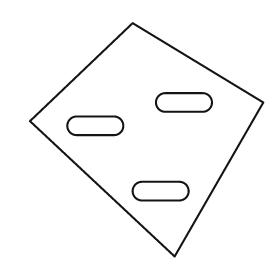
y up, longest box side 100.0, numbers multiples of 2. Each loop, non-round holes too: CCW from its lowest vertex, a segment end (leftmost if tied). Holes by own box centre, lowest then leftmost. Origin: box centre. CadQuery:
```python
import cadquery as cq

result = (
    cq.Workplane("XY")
    .moveTo(12.0, -50.0)
    .lineTo(50.0, 16.0)
    .lineTo(-6.0, 50.0)
    .lineTo(-50.0, 8.0)
    .close()
    .moveTo(-2.0, -26.0)
    .lineTo(14.0, -26.0)
    .threePointArc((18.0, -22.0), (14.0, -18.0))
    .lineTo(-2.0, -18.0)
    .threePointArc((-6.0, -22.0), (-2.0, -26.0))
    .close()
    .moveTo(-30.0, 2.0)
    .lineTo(-14.0, 2.0)
    .threePointArc((-10.0, 6.0), (-14.0, 10.0))
    .lineTo(-30.0, 10.0)
    .threePointArc((-34.0, 6.0), (-30.0, 2.0))
    .close()
    .moveTo(8.0, 12.0)
    .lineTo(24.0, 12.0)
    .threePointArc((28.0, 16.0), (24.0, 20.0))
    .lineTo(8.0, 20.0)
    .threePointArc((4.0, 16.0), (8.0, 12.0))
    .close()
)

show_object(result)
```